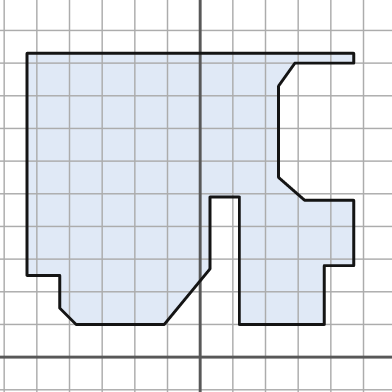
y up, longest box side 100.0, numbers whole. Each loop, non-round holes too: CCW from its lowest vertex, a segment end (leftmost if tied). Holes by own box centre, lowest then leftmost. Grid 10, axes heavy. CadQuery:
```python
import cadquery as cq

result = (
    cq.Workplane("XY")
    .moveTo(-38.0, 10.0)
    .lineTo(-11.0, 10.0)
    .lineTo(3.0, 27.0)
    .lineTo(3.0, 49.0)
    .lineTo(12.0, 49.0)
    .lineTo(12.0, 10.0)
    .lineTo(38.0, 10.0)
    .lineTo(38.0, 28.0)
    .lineTo(47.0, 28.0)
    .lineTo(47.0, 48.0)
    .lineTo(32.0, 48.0)
    .lineTo(24.0, 55.0)
    .lineTo(24.0, 83.0)
    .lineTo(29.0, 90.0)
    .lineTo(47.0, 90.0)
    .lineTo(47.0, 93.0)
    .lineTo(-53.0, 93.0)
    .lineTo(-53.0, 25.0)
    .lineTo(-43.0, 25.0)
    .lineTo(-43.0, 15.0)
    .close()
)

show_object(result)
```